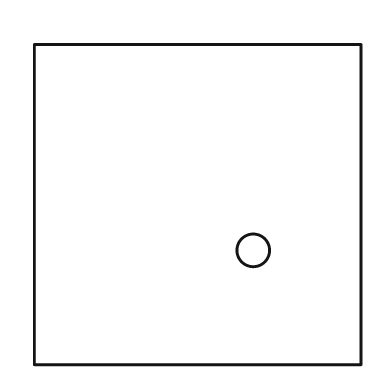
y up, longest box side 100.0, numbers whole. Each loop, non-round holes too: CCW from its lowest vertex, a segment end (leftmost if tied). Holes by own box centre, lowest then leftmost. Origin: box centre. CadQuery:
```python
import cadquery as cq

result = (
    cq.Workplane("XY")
    .moveTo(-50.0, -49.0)
    .lineTo(50.0, -49.0)
    .lineTo(50.0, 49.0)
    .lineTo(-50.0, 49.0)
    .close()
    .moveTo(17.0, -14.0)
    .circle(5.0)
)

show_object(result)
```